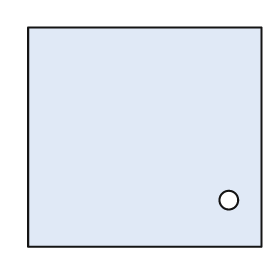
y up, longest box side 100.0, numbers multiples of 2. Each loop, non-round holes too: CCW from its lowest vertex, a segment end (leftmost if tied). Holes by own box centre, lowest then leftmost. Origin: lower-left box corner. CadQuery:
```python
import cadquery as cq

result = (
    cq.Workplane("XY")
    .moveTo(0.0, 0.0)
    .lineTo(100.0, 0.0)
    .lineTo(100.0, 94.0)
    .lineTo(0.0, 94.0)
    .close()
    .moveTo(86.0, 20.0)
    .circle(4.0)
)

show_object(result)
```